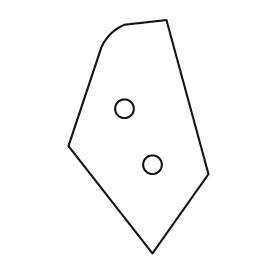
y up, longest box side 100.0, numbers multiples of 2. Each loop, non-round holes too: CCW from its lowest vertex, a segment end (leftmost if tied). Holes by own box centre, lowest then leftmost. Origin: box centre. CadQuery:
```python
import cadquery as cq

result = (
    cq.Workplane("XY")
    .moveTo(6.0, -50.0)
    .lineTo(30.0, -16.0)
    .lineTo(12.0, 50.0)
    .lineTo(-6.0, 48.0)
    .threePointArc((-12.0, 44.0), (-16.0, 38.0))
    .lineTo(-30.0, -4.0)
    .close()
    .moveTo(6.0, -12.0)
    .circle(4.0)
    .moveTo(-6.0, 12.0)
    .circle(4.0)
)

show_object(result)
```